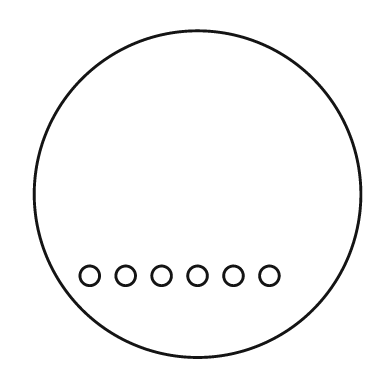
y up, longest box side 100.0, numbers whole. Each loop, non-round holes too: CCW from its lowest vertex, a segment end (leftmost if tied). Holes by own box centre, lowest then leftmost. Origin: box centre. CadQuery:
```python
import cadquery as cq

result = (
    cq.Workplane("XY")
    .moveTo(0.0, 0.0)
    .circle(50.0)
    .moveTo(-33.0, -25.0)
    .circle(3.0)
    .moveTo(-22.0, -25.0)
    .circle(3.0)
    .moveTo(-11.0, -25.0)
    .circle(3.0)
    .moveTo(0.0, -25.0)
    .circle(3.0)
    .moveTo(11.0, -25.0)
    .circle(3.0)
    .moveTo(22.0, -25.0)
    .circle(3.0)
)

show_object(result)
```